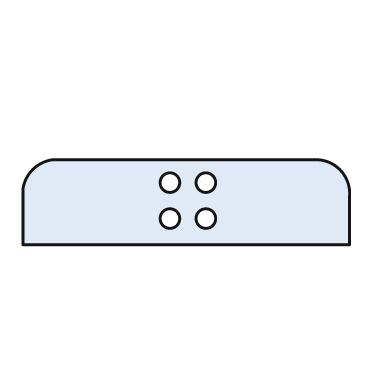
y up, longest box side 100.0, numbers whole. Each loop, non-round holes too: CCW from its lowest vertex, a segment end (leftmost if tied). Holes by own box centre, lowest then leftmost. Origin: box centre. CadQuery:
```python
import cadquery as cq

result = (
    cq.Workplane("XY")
    .moveTo(-50.0, -13.0)
    .lineTo(50.0, -13.0)
    .lineTo(50.0, 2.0)
    .threePointArc((47.0, 10.0), (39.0, 13.0))
    .lineTo(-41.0, 13.0)
    .threePointArc((-47.0, 10.0), (-50.0, 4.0))
    .close()
    .moveTo(-5.0, -5.0)
    .circle(3.0)
    .moveTo(6.0, -5.0)
    .circle(3.0)
    .moveTo(-5.0, 6.0)
    .circle(3.0)
    .moveTo(6.0, 6.0)
    .circle(3.0)
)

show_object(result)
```